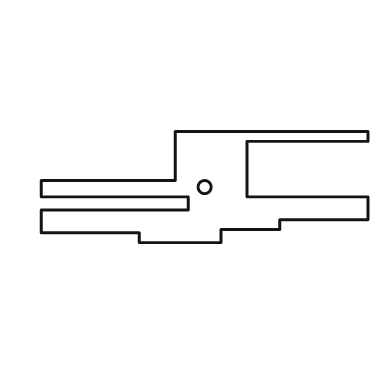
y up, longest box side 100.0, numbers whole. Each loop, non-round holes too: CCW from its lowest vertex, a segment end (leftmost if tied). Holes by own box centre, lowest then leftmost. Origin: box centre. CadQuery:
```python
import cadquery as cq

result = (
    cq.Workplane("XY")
    .moveTo(-20.0, -17.0)
    .lineTo(5.0, -17.0)
    .lineTo(5.0, -13.0)
    .lineTo(23.0, -13.0)
    .lineTo(23.0, -10.0)
    .lineTo(50.0, -10.0)
    .lineTo(50.0, -3.0)
    .lineTo(13.0, -3.0)
    .lineTo(13.0, 14.0)
    .lineTo(50.0, 14.0)
    .lineTo(50.0, 17.0)
    .lineTo(-9.0, 17.0)
    .lineTo(-9.0, 2.0)
    .lineTo(-50.0, 2.0)
    .lineTo(-50.0, -3.0)
    .lineTo(-5.0, -3.0)
    .lineTo(-5.0, -7.0)
    .lineTo(-50.0, -7.0)
    .lineTo(-50.0, -14.0)
    .lineTo(-20.0, -14.0)
    .close()
    .moveTo(0.0, 0.0)
    .circle(2.0)
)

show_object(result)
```